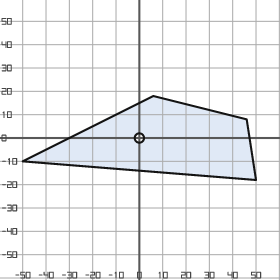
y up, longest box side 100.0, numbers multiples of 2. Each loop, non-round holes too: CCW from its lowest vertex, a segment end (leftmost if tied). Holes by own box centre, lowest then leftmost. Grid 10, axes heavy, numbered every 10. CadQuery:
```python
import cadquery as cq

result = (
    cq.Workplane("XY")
    .moveTo(50.0, -18.0)
    .lineTo(46.0, 8.0)
    .lineTo(6.0, 18.0)
    .lineTo(-50.0, -10.0)
    .close()
    .moveTo(0.0, 0.0)
    .circle(2.0)
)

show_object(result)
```